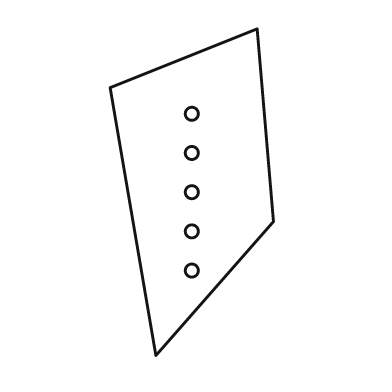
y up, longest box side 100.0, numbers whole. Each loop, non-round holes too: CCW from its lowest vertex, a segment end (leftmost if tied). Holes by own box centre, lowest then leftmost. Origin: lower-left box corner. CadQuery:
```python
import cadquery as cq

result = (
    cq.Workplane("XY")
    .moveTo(14.0, 0.0)
    .lineTo(50.0, 41.0)
    .lineTo(45.0, 100.0)
    .lineTo(0.0, 82.0)
    .close()
    .moveTo(25.0, 26.0)
    .circle(2.0)
    .moveTo(25.0, 38.0)
    .circle(2.0)
    .moveTo(25.0, 50.0)
    .circle(2.0)
    .moveTo(25.0, 62.0)
    .circle(2.0)
    .moveTo(25.0, 74.0)
    .circle(2.0)
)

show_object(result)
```